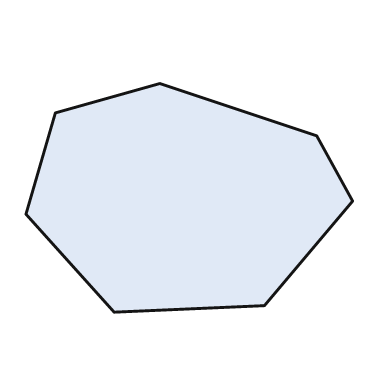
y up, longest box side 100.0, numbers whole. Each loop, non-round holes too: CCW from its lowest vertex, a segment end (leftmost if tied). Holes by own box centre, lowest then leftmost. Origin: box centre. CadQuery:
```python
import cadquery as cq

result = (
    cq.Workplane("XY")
    .moveTo(-23.0, -35.0)
    .lineTo(23.0, -33.0)
    .lineTo(50.0, -1.0)
    .lineTo(39.0, 19.0)
    .lineTo(-9.0, 35.0)
    .lineTo(-41.0, 26.0)
    .lineTo(-50.0, -5.0)
    .close()
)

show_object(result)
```